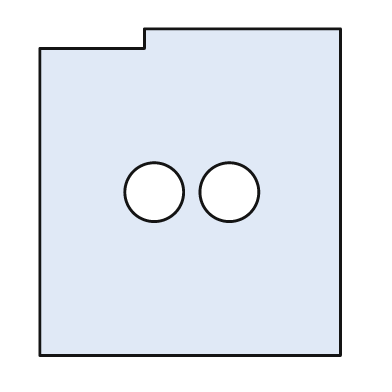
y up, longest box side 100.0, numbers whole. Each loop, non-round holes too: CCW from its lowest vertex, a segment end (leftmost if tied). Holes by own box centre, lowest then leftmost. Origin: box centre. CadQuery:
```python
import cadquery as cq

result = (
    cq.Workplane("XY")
    .moveTo(-46.0, -50.0)
    .lineTo(46.0, -50.0)
    .lineTo(46.0, 50.0)
    .lineTo(-14.0, 50.0)
    .lineTo(-14.0, 44.0)
    .lineTo(-46.0, 44.0)
    .close()
    .moveTo(-11.0, 0.0)
    .circle(9.0)
    .moveTo(12.0, 0.0)
    .circle(9.0)
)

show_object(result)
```